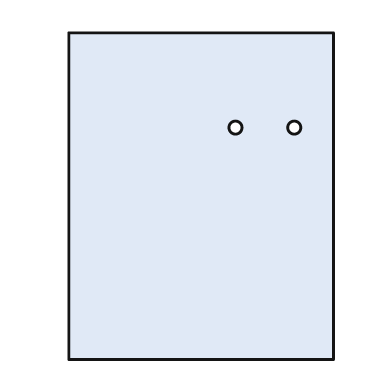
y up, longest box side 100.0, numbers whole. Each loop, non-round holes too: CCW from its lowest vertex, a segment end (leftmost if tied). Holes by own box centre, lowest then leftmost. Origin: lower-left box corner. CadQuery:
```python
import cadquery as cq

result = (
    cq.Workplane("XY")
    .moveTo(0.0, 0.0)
    .lineTo(81.0, 0.0)
    .lineTo(81.0, 100.0)
    .lineTo(0.0, 100.0)
    .close()
    .moveTo(51.0, 71.0)
    .circle(2.0)
    .moveTo(69.0, 71.0)
    .circle(2.0)
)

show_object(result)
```